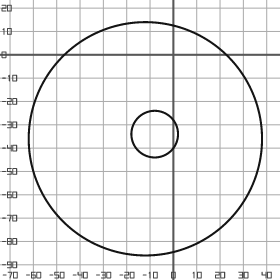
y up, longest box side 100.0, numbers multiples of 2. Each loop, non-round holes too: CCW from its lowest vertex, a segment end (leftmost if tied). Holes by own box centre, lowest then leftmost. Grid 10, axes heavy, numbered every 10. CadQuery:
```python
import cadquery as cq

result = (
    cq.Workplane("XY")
    .moveTo(-12.0, -36.0)
    .circle(50.0)
    .moveTo(-8.0, -34.0)
    .circle(10.0)
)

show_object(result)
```